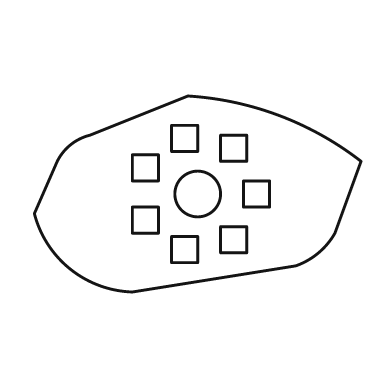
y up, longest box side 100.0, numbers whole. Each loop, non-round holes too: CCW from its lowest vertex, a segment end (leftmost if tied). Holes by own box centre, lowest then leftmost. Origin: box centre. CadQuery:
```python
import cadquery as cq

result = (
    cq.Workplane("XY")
    .moveTo(-20.0, -30.0)
    .lineTo(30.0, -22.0)
    .threePointArc((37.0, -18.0), (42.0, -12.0))
    .lineTo(50.0, 10.0)
    .threePointArc((25.0, 24.0), (-3.0, 30.0))
    .lineTo(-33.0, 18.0)
    .threePointArc((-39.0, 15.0), (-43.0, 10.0))
    .lineTo(-50.0, -6.0)
    .threePointArc((-39.0, -23.0), (-20.0, -30.0))
    .close()
    .moveTo(-8.0, -21.0)
    .lineTo(0.0, -21.0)
    .lineTo(0.0, -13.0)
    .lineTo(-8.0, -13.0)
    .close()
    .moveTo(7.0, -18.0)
    .lineTo(15.0, -18.0)
    .lineTo(15.0, -10.0)
    .lineTo(7.0, -10.0)
    .close()
    .moveTo(-20.0, -12.0)
    .lineTo(-12.0, -12.0)
    .lineTo(-12.0, -4.0)
    .lineTo(-20.0, -4.0)
    .close()
    .moveTo(0.0, 0.0)
    .circle(7.0)
    .moveTo(14.0, -4.0)
    .lineTo(22.0, -4.0)
    .lineTo(22.0, 4.0)
    .lineTo(14.0, 4.0)
    .close()
    .moveTo(-20.0, 4.0)
    .lineTo(-12.0, 4.0)
    .lineTo(-12.0, 12.0)
    .lineTo(-20.0, 12.0)
    .close()
    .moveTo(7.0, 10.0)
    .lineTo(15.0, 10.0)
    .lineTo(15.0, 18.0)
    .lineTo(7.0, 18.0)
    .close()
    .moveTo(-8.0, 13.0)
    .lineTo(0.0, 13.0)
    .lineTo(0.0, 21.0)
    .lineTo(-8.0, 21.0)
    .close()
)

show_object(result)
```